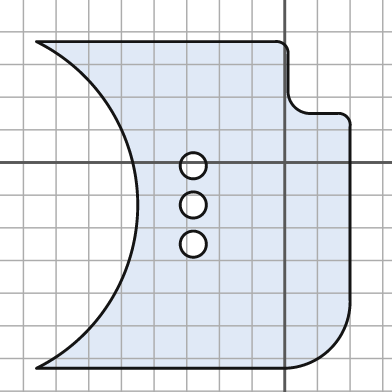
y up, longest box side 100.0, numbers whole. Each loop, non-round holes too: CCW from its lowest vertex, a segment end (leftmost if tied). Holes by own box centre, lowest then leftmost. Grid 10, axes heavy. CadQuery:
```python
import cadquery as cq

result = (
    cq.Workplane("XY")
    .moveTo(-76.0, -63.0)
    .lineTo(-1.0, -63.0)
    .threePointArc((14.0, -57.0), (20.0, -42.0))
    .lineTo(20.0, 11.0)
    .threePointArc((19.0, 14.0), (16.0, 15.0))
    .lineTo(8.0, 15.0)
    .threePointArc((3.0, 17.0), (1.0, 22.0))
    .lineTo(1.0, 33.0)
    .threePointArc((0.0, 36.0), (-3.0, 37.0))
    .lineTo(-76.0, 37.0)
    .threePointArc((-45.0, -13.0), (-76.0, -63.0))
    .close()
    .moveTo(-28.0, -25.0)
    .circle(4.0)
    .moveTo(-28.0, -13.0)
    .circle(4.0)
    .moveTo(-28.0, -1.0)
    .circle(4.0)
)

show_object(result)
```